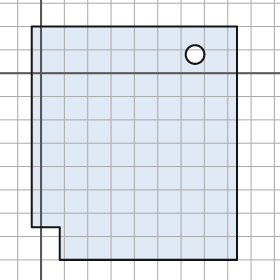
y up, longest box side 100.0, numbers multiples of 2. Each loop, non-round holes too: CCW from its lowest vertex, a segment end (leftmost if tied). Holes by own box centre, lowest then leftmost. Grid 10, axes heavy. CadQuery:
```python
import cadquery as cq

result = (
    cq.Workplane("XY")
    .moveTo(8.0, -80.0)
    .lineTo(84.0, -80.0)
    .lineTo(84.0, 20.0)
    .lineTo(-4.0, 20.0)
    .lineTo(-4.0, -66.0)
    .lineTo(8.0, -66.0)
    .close()
    .moveTo(66.0, 8.0)
    .circle(4.0)
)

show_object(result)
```